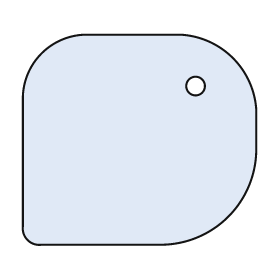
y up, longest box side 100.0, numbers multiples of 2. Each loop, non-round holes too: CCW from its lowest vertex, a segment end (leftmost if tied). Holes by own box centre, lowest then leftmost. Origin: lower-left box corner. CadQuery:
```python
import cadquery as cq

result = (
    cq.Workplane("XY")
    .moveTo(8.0, 0.0)
    .lineTo(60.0, 0.0)
    .threePointArc((88.0, 12.0), (100.0, 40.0))
    .lineTo(100.0, 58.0)
    .threePointArc((90.0, 80.0), (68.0, 90.0))
    .lineTo(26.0, 90.0)
    .threePointArc((8.0, 82.0), (0.0, 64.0))
    .lineTo(0.0, 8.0)
    .threePointArc((2.0, 2.0), (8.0, 0.0))
    .close()
    .moveTo(74.0, 68.0)
    .circle(4.0)
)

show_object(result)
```